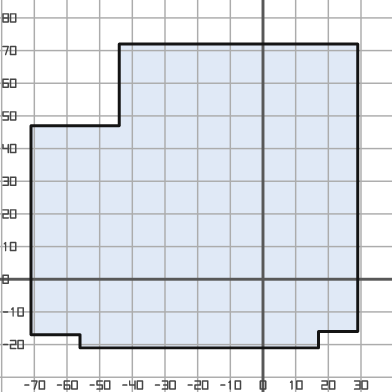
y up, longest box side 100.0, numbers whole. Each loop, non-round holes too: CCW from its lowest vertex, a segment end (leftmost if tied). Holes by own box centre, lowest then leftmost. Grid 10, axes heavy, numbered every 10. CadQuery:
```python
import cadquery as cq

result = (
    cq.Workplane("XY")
    .moveTo(-56.0, -21.0)
    .lineTo(17.0, -21.0)
    .lineTo(17.0, -16.0)
    .lineTo(29.0, -16.0)
    .lineTo(29.0, 72.0)
    .lineTo(-44.0, 72.0)
    .lineTo(-44.0, 47.0)
    .lineTo(-71.0, 47.0)
    .lineTo(-71.0, -17.0)
    .lineTo(-56.0, -17.0)
    .close()
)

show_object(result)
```